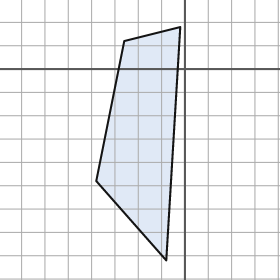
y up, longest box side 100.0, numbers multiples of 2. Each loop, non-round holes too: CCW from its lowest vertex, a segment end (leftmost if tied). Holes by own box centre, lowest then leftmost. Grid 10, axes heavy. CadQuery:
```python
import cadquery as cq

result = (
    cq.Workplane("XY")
    .moveTo(-8.0, -82.0)
    .lineTo(-2.0, 18.0)
    .lineTo(-26.0, 12.0)
    .lineTo(-38.0, -48.0)
    .close()
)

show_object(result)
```